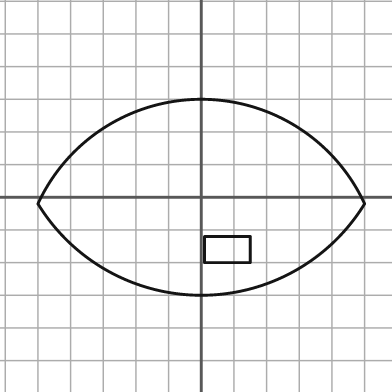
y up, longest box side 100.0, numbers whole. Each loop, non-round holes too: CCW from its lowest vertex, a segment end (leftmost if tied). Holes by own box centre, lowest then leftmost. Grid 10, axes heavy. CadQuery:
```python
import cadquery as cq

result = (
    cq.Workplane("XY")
    .moveTo(-50.0, -2.0)
    .threePointArc((0.0, -30.0), (50.0, -2.0))
    .threePointArc((0.0, 30.0), (-50.0, -2.0))
    .close()
    .moveTo(1.0, -20.0)
    .lineTo(15.0, -20.0)
    .lineTo(15.0, -12.0)
    .lineTo(1.0, -12.0)
    .close()
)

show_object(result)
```